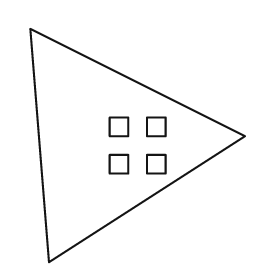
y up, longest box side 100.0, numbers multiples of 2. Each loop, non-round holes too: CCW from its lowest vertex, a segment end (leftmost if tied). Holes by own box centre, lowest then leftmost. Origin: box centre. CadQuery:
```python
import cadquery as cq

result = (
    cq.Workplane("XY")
    .moveTo(-38.0, -50.0)
    .lineTo(46.0, 4.0)
    .lineTo(-46.0, 50.0)
    .close()
    .moveTo(-12.0, -12.0)
    .lineTo(-4.0, -12.0)
    .lineTo(-4.0, -4.0)
    .lineTo(-12.0, -4.0)
    .close()
    .moveTo(4.0, -12.0)
    .lineTo(12.0, -12.0)
    .lineTo(12.0, -4.0)
    .lineTo(4.0, -4.0)
    .close()
    .moveTo(-12.0, 4.0)
    .lineTo(-4.0, 4.0)
    .lineTo(-4.0, 12.0)
    .lineTo(-12.0, 12.0)
    .close()
    .moveTo(4.0, 4.0)
    .lineTo(12.0, 4.0)
    .lineTo(12.0, 12.0)
    .lineTo(4.0, 12.0)
    .close()
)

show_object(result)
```